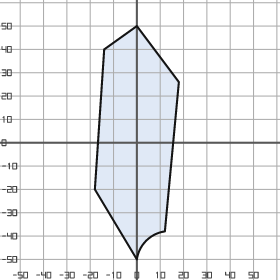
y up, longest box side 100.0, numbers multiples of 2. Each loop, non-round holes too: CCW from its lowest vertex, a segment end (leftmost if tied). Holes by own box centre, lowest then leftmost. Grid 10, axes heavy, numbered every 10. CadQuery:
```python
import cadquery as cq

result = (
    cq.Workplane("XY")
    .moveTo(0.0, -50.0)
    .threePointArc((4.0, -42.0), (12.0, -38.0))
    .lineTo(18.0, 26.0)
    .lineTo(0.0, 50.0)
    .lineTo(-14.0, 40.0)
    .lineTo(-18.0, -20.0)
    .close()
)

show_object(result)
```